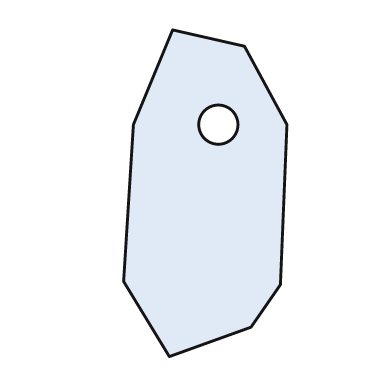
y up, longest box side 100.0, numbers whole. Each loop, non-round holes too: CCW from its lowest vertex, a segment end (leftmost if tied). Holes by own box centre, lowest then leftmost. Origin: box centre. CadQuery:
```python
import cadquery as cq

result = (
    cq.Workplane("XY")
    .moveTo(-11.0, -50.0)
    .lineTo(14.0, -41.0)
    .lineTo(23.0, -28.0)
    .lineTo(25.0, 21.0)
    .lineTo(12.0, 45.0)
    .lineTo(-10.0, 50.0)
    .lineTo(-22.0, 21.0)
    .lineTo(-25.0, -27.0)
    .close()
    .moveTo(4.0, 21.0)
    .circle(6.0)
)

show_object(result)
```